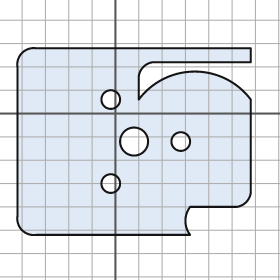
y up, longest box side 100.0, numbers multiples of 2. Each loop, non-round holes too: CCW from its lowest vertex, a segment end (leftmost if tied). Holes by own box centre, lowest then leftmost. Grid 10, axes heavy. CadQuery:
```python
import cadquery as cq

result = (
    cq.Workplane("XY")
    .moveTo(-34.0, -52.0)
    .lineTo(32.0, -52.0)
    .threePointArc((30.0, -46.0), (32.0, -40.0))
    .lineTo(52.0, -40.0)
    .threePointArc((56.0, -38.0), (58.0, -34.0))
    .lineTo(58.0, 6.0)
    .threePointArc((34.0, 18.0), (10.0, 6.0))
    .lineTo(10.0, 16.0)
    .threePointArc((12.0, 20.0), (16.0, 22.0))
    .lineTo(58.0, 22.0)
    .lineTo(58.0, 28.0)
    .lineTo(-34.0, 28.0)
    .threePointArc((-40.0, 26.0), (-42.0, 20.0))
    .lineTo(-42.0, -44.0)
    .threePointArc((-40.0, -50.0), (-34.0, -52.0))
    .close()
    .moveTo(-2.0, -30.0)
    .circle(4.0)
    .moveTo(8.0, -12.0)
    .circle(6.0)
    .moveTo(28.0, -12.0)
    .circle(4.0)
    .moveTo(-2.0, 6.0)
    .circle(4.0)
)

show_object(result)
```